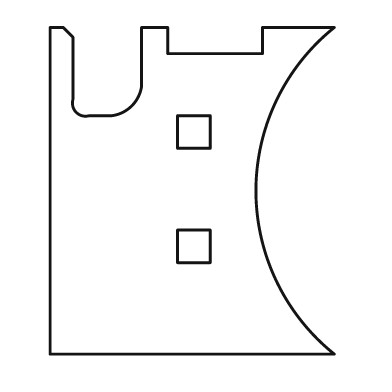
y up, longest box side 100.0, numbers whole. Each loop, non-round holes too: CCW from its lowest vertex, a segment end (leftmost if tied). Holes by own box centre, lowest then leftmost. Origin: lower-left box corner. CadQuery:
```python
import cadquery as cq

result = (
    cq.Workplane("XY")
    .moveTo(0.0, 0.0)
    .lineTo(87.0, 0.0)
    .threePointArc((63.0, 50.0), (87.0, 100.0))
    .lineTo(65.0, 100.0)
    .lineTo(65.0, 92.0)
    .lineTo(36.0, 92.0)
    .lineTo(36.0, 100.0)
    .lineTo(28.0, 100.0)
    .lineTo(28.0, 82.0)
    .threePointArc((25.0, 76.0), (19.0, 73.0))
    .lineTo(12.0, 73.0)
    .threePointArc((8.0, 74.0), (7.0, 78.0))
    .lineTo(7.0, 97.0)
    .lineTo(4.0, 100.0)
    .lineTo(0.0, 100.0)
    .close()
    .moveTo(39.0, 28.0)
    .lineTo(49.0, 28.0)
    .lineTo(49.0, 38.0)
    .lineTo(39.0, 38.0)
    .close()
    .moveTo(39.0, 63.0)
    .lineTo(49.0, 63.0)
    .lineTo(49.0, 73.0)
    .lineTo(39.0, 73.0)
    .close()
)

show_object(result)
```